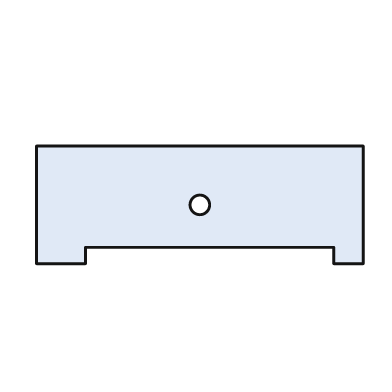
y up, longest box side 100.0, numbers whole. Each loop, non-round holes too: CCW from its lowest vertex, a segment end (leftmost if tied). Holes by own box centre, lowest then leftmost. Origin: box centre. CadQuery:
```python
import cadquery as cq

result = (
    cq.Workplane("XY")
    .moveTo(-50.0, -18.0)
    .lineTo(-35.0, -18.0)
    .lineTo(-35.0, -13.0)
    .lineTo(41.0, -13.0)
    .lineTo(41.0, -18.0)
    .lineTo(50.0, -18.0)
    .lineTo(50.0, 18.0)
    .lineTo(-50.0, 18.0)
    .close()
    .moveTo(0.0, 0.0)
    .circle(3.0)
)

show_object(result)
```